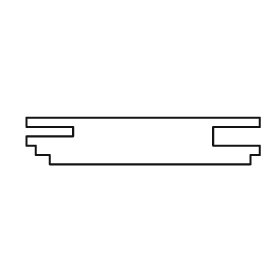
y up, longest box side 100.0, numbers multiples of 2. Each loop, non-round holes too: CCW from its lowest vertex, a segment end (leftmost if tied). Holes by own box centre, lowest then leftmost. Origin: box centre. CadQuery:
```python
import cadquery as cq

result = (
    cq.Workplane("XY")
    .moveTo(-40.0, -10.0)
    .lineTo(46.0, -10.0)
    .lineTo(46.0, -6.0)
    .lineTo(50.0, -6.0)
    .lineTo(50.0, -2.0)
    .lineTo(30.0, -2.0)
    .lineTo(30.0, 6.0)
    .lineTo(50.0, 6.0)
    .lineTo(50.0, 10.0)
    .lineTo(-50.0, 10.0)
    .lineTo(-50.0, 6.0)
    .lineTo(-30.0, 6.0)
    .lineTo(-30.0, 2.0)
    .lineTo(-50.0, 2.0)
    .lineTo(-50.0, -2.0)
    .lineTo(-46.0, -2.0)
    .lineTo(-46.0, -6.0)
    .lineTo(-40.0, -6.0)
    .close()
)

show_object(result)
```